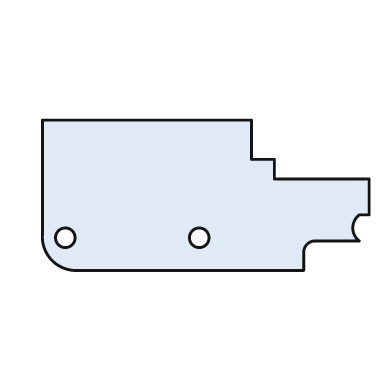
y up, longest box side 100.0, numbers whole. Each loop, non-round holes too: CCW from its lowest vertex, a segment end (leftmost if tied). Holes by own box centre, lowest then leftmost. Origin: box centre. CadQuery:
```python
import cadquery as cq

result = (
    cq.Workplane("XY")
    .moveTo(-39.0, -23.0)
    .lineTo(30.0, -23.0)
    .lineTo(30.0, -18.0)
    .threePointArc((31.0, -15.0), (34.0, -14.0))
    .lineTo(47.0, -14.0)
    .threePointArc((45.0, -10.0), (47.0, -6.0))
    .lineTo(50.0, -6.0)
    .lineTo(50.0, 5.0)
    .lineTo(21.0, 5.0)
    .lineTo(21.0, 11.0)
    .lineTo(14.0, 11.0)
    .lineTo(14.0, 23.0)
    .lineTo(-50.0, 23.0)
    .lineTo(-50.0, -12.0)
    .threePointArc((-47.0, -20.0), (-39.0, -23.0))
    .close()
    .moveTo(-43.0, -13.0)
    .circle(3.0)
    .moveTo(-2.0, -13.0)
    .circle(3.0)
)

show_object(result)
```